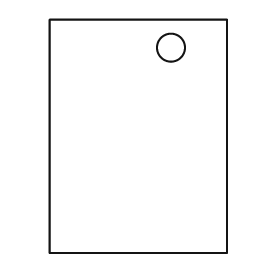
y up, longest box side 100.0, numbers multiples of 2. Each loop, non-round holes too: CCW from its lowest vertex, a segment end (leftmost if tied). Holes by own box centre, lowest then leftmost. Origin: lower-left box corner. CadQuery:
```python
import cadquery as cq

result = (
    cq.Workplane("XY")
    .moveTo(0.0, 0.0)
    .lineTo(76.0, 0.0)
    .lineTo(76.0, 100.0)
    .lineTo(0.0, 100.0)
    .close()
    .moveTo(52.0, 88.0)
    .circle(6.0)
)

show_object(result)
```